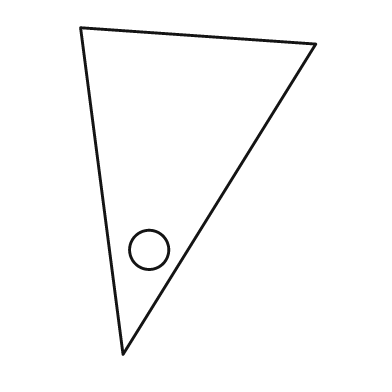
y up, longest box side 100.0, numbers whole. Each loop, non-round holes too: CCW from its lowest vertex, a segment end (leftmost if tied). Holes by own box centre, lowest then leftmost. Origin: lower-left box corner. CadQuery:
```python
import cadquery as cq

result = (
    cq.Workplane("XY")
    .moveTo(13.0, 0.0)
    .lineTo(72.0, 95.0)
    .lineTo(0.0, 100.0)
    .close()
    .moveTo(21.0, 32.0)
    .circle(6.0)
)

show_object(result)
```